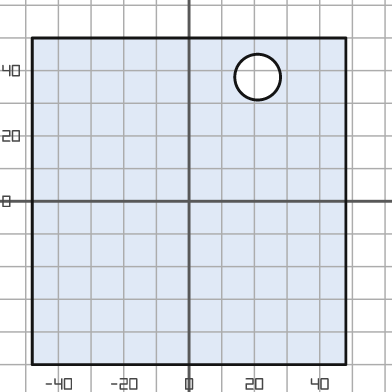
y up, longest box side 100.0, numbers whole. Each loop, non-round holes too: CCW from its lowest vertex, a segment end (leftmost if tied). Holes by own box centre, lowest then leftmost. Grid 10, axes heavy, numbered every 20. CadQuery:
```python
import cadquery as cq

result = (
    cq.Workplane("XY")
    .moveTo(-48.0, -50.0)
    .lineTo(48.0, -50.0)
    .lineTo(48.0, 50.0)
    .lineTo(-48.0, 50.0)
    .close()
    .moveTo(21.0, 38.0)
    .circle(7.0)
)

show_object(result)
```